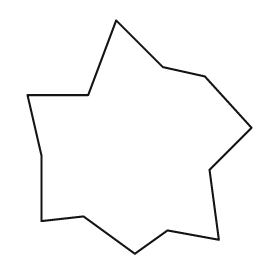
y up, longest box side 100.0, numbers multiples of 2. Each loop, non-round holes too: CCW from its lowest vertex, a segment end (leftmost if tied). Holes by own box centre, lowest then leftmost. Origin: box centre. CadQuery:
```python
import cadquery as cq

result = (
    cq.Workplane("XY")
    .moveTo(-2.0, -50.0)
    .lineTo(12.0, -40.0)
    .lineTo(34.0, -44.0)
    .lineTo(30.0, -14.0)
    .lineTo(48.0, 4.0)
    .lineTo(28.0, 26.0)
    .lineTo(10.0, 30.0)
    .lineTo(-10.0, 50.0)
    .lineTo(-22.0, 18.0)
    .lineTo(-48.0, 18.0)
    .lineTo(-42.0, -8.0)
    .lineTo(-42.0, -36.0)
    .lineTo(-24.0, -34.0)
    .close()
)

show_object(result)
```